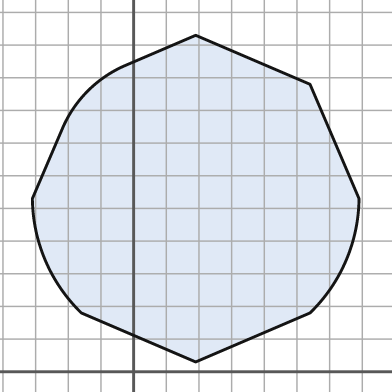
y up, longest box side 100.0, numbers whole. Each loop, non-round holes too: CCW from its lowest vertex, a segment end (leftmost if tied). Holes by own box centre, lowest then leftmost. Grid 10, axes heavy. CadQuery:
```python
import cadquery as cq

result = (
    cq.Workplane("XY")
    .moveTo(19.0, 3.0)
    .lineTo(54.0, 18.0)
    .threePointArc((65.0, 34.0), (69.0, 53.0))
    .lineTo(54.0, 88.0)
    .lineTo(19.0, 103.0)
    .lineTo(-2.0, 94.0)
    .threePointArc((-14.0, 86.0), (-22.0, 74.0))
    .lineTo(-31.0, 53.0)
    .threePointArc((-27.0, 34.0), (-16.0, 18.0))
    .close()
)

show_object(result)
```